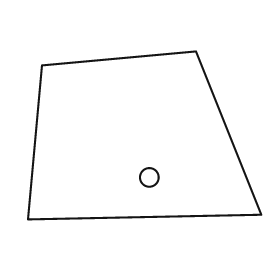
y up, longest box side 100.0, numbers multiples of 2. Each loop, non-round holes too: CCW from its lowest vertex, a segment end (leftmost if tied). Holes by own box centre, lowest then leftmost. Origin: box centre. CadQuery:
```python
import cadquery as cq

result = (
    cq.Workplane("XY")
    .moveTo(-50.0, -36.0)
    .lineTo(50.0, -34.0)
    .lineTo(22.0, 36.0)
    .lineTo(-44.0, 30.0)
    .close()
    .moveTo(2.0, -18.0)
    .circle(4.0)
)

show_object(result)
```